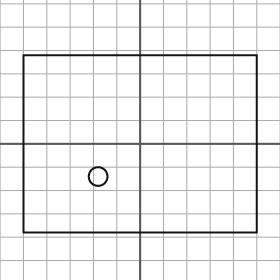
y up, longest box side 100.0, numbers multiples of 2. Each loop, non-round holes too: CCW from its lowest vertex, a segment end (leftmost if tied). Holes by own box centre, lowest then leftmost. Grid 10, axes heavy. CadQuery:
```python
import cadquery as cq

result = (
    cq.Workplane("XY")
    .moveTo(-50.0, -38.0)
    .lineTo(50.0, -38.0)
    .lineTo(50.0, 38.0)
    .lineTo(-50.0, 38.0)
    .close()
    .moveTo(-18.0, -14.0)
    .circle(4.0)
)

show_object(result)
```